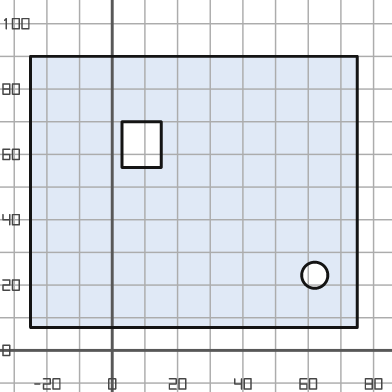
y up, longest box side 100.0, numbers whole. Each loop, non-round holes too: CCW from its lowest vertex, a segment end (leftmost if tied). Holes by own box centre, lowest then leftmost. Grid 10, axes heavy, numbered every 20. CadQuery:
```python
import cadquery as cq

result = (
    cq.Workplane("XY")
    .moveTo(-25.0, 7.0)
    .lineTo(75.0, 7.0)
    .lineTo(75.0, 90.0)
    .lineTo(-25.0, 90.0)
    .close()
    .moveTo(62.0, 23.0)
    .circle(4.0)
    .moveTo(3.0, 56.0)
    .lineTo(15.0, 56.0)
    .lineTo(15.0, 70.0)
    .lineTo(3.0, 70.0)
    .close()
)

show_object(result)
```